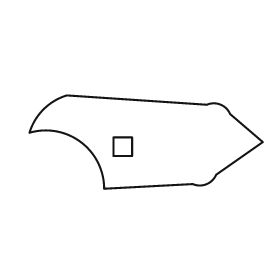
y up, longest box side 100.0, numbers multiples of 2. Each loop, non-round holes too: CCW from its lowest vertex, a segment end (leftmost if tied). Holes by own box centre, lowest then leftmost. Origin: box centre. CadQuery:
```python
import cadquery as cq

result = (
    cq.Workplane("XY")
    .moveTo(-18.0, -20.0)
    .lineTo(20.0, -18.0)
    .threePointArc((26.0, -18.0), (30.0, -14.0))
    .lineTo(50.0, 0.0)
    .lineTo(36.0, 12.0)
    .threePointArc((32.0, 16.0), (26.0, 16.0))
    .lineTo(-34.0, 20.0)
    .threePointArc((-44.0, 14.0), (-50.0, 4.0))
    .threePointArc((-28.0, 0.0), (-18.0, -20.0))
    .close()
    .moveTo(-14.0, -6.0)
    .lineTo(-6.0, -6.0)
    .lineTo(-6.0, 2.0)
    .lineTo(-14.0, 2.0)
    .close()
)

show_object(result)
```